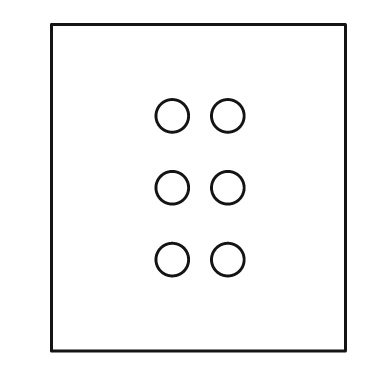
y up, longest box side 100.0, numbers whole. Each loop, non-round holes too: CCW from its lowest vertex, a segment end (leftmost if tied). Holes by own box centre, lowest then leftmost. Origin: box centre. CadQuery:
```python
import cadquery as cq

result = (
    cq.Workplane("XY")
    .moveTo(-45.0, -50.0)
    .lineTo(45.0, -50.0)
    .lineTo(45.0, 50.0)
    .lineTo(-45.0, 50.0)
    .close()
    .moveTo(-8.0, -22.0)
    .circle(5.0)
    .moveTo(9.0, -22.0)
    .circle(5.0)
    .moveTo(-8.0, 0.0)
    .circle(5.0)
    .moveTo(9.0, 0.0)
    .circle(5.0)
    .moveTo(-8.0, 22.0)
    .circle(5.0)
    .moveTo(9.0, 22.0)
    .circle(5.0)
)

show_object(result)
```